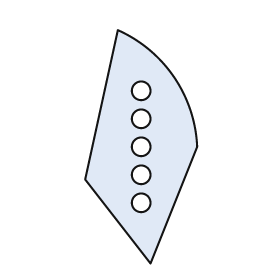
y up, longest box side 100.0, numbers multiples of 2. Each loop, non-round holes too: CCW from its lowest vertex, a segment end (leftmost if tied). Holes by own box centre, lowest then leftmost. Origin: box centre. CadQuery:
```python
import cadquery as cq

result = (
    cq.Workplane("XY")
    .moveTo(4.0, -50.0)
    .lineTo(24.0, 0.0)
    .threePointArc((14.0, 30.0), (-10.0, 50.0))
    .lineTo(-24.0, -14.0)
    .close()
    .moveTo(0.0, -24.0)
    .circle(4.0)
    .moveTo(0.0, -12.0)
    .circle(4.0)
    .moveTo(0.0, 0.0)
    .circle(4.0)
    .moveTo(0.0, 12.0)
    .circle(4.0)
    .moveTo(0.0, 24.0)
    .circle(4.0)
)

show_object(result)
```